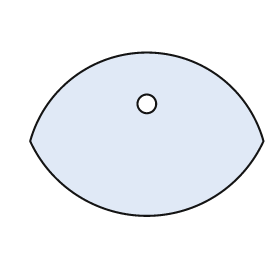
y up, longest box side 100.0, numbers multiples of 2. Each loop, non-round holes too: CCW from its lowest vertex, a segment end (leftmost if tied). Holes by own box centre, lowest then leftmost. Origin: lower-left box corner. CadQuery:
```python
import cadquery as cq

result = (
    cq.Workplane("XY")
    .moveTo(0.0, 32.0)
    .threePointArc((50.0, 0.0), (100.0, 32.0))
    .threePointArc((50.0, 70.0), (0.0, 32.0))
    .close()
    .moveTo(50.0, 48.0)
    .circle(4.0)
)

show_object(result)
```